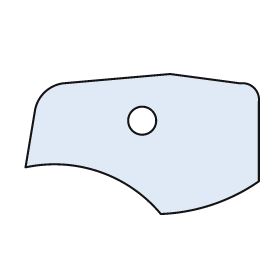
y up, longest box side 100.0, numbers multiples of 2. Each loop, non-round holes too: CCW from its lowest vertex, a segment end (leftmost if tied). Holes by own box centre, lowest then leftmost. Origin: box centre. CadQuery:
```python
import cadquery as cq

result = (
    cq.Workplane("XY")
    .moveTo(8.0, -30.0)
    .threePointArc((30.0, -26.0), (50.0, -16.0))
    .lineTo(50.0, 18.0)
    .threePointArc((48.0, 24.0), (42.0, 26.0))
    .lineTo(12.0, 30.0)
    .lineTo(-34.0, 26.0)
    .threePointArc((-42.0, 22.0), (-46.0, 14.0))
    .lineTo(-50.0, -10.0)
    .threePointArc((-18.0, -12.0), (8.0, -30.0))
    .close()
    .moveTo(0.0, 10.0)
    .circle(6.0)
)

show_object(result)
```